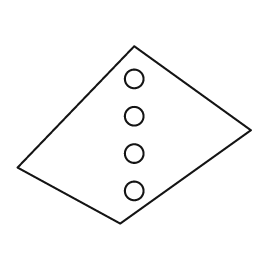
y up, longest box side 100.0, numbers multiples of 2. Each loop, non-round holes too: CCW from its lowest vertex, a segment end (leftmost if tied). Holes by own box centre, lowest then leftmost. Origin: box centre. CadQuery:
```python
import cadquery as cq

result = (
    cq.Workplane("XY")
    .moveTo(-6.0, -38.0)
    .lineTo(50.0, 2.0)
    .lineTo(0.0, 38.0)
    .lineTo(-50.0, -14.0)
    .close()
    .moveTo(0.0, -24.0)
    .circle(4.0)
    .moveTo(0.0, -8.0)
    .circle(4.0)
    .moveTo(0.0, 8.0)
    .circle(4.0)
    .moveTo(0.0, 24.0)
    .circle(4.0)
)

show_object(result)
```